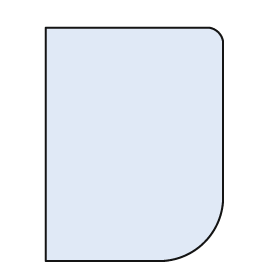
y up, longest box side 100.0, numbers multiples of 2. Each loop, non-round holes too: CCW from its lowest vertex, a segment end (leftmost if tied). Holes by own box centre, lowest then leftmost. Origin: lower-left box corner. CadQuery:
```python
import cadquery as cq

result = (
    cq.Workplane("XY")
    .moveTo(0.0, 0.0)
    .lineTo(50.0, 0.0)
    .threePointArc((68.0, 8.0), (76.0, 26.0))
    .lineTo(76.0, 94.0)
    .threePointArc((74.0, 98.0), (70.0, 100.0))
    .lineTo(0.0, 100.0)
    .close()
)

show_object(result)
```